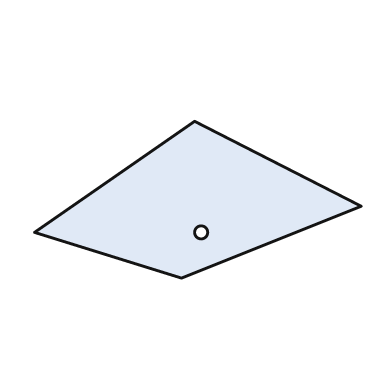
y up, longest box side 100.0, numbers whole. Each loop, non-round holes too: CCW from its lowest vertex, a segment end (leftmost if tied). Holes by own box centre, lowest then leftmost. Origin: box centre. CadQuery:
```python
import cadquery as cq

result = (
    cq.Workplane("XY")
    .moveTo(-5.0, -24.0)
    .lineTo(50.0, -2.0)
    .lineTo(-1.0, 24.0)
    .lineTo(-50.0, -10.0)
    .close()
    .moveTo(1.0, -10.0)
    .circle(2.0)
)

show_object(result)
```